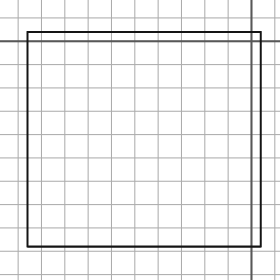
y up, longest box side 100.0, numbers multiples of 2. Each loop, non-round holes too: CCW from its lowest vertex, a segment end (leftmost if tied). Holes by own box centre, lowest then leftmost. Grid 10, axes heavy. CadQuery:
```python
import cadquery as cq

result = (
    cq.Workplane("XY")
    .moveTo(-96.0, -88.0)
    .lineTo(4.0, -88.0)
    .lineTo(4.0, 4.0)
    .lineTo(-96.0, 4.0)
    .close()
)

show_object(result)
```